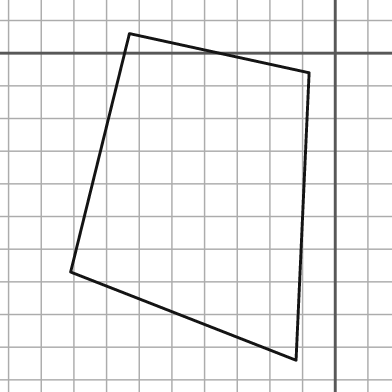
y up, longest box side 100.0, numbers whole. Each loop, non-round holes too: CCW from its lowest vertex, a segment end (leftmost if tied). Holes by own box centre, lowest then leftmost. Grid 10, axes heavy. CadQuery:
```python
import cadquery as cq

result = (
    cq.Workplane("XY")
    .moveTo(-12.0, -94.0)
    .lineTo(-8.0, -6.0)
    .lineTo(-63.0, 6.0)
    .lineTo(-81.0, -67.0)
    .close()
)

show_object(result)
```